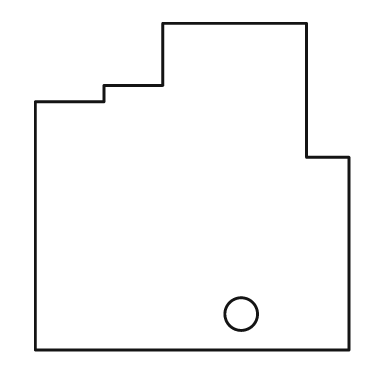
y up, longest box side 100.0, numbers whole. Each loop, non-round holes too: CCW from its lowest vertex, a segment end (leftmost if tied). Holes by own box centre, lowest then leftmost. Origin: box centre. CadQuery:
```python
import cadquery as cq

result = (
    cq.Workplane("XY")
    .moveTo(-48.0, -50.0)
    .lineTo(48.0, -50.0)
    .lineTo(48.0, 9.0)
    .lineTo(35.0, 9.0)
    .lineTo(35.0, 50.0)
    .lineTo(-9.0, 50.0)
    .lineTo(-9.0, 31.0)
    .lineTo(-27.0, 31.0)
    .lineTo(-27.0, 26.0)
    .lineTo(-48.0, 26.0)
    .close()
    .moveTo(15.0, -39.0)
    .circle(5.0)
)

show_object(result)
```